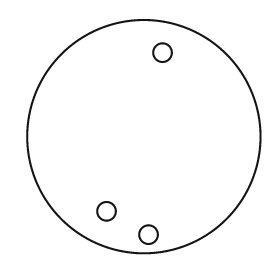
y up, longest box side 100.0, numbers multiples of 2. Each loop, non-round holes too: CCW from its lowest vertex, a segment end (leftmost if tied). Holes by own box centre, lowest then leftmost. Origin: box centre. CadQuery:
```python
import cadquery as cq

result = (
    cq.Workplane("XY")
    .moveTo(0.0, 0.0)
    .circle(50.0)
    .moveTo(2.0, -42.0)
    .circle(4.0)
    .moveTo(-16.0, -32.0)
    .circle(4.0)
    .moveTo(8.0, 36.0)
    .circle(4.0)
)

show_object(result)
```